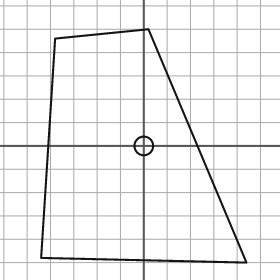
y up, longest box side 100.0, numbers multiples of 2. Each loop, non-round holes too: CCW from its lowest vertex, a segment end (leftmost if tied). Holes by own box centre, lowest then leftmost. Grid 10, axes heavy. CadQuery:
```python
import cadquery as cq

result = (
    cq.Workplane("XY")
    .moveTo(44.0, -50.0)
    .lineTo(2.0, 50.0)
    .lineTo(-38.0, 46.0)
    .lineTo(-44.0, -48.0)
    .close()
    .moveTo(0.0, 0.0)
    .circle(4.0)
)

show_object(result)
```